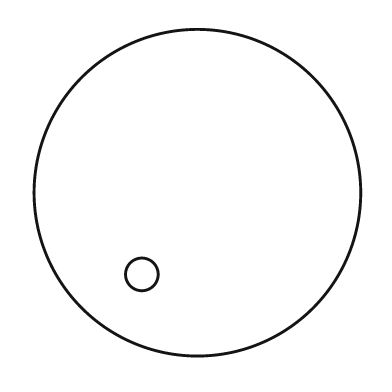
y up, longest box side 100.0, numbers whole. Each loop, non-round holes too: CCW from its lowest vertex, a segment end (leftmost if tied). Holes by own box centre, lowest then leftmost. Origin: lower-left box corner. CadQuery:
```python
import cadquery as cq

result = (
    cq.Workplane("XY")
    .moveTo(50.0, 50.0)
    .circle(50.0)
    .moveTo(33.0, 25.0)
    .circle(5.0)
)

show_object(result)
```